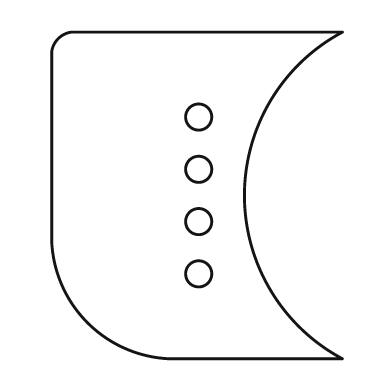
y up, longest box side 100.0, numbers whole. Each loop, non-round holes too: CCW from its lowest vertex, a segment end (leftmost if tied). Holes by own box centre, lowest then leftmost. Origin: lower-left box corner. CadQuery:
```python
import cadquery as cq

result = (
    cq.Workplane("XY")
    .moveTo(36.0, 0.0)
    .lineTo(89.0, 0.0)
    .threePointArc((59.0, 50.0), (89.0, 100.0))
    .lineTo(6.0, 100.0)
    .threePointArc((2.0, 98.0), (0.0, 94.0))
    .lineTo(0.0, 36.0)
    .threePointArc((11.0, 11.0), (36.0, 0.0))
    .close()
    .moveTo(45.0, 26.0)
    .circle(4.0)
    .moveTo(45.0, 42.0)
    .circle(4.0)
    .moveTo(45.0, 58.0)
    .circle(4.0)
    .moveTo(45.0, 74.0)
    .circle(4.0)
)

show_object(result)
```